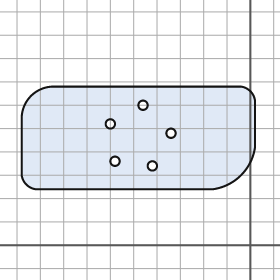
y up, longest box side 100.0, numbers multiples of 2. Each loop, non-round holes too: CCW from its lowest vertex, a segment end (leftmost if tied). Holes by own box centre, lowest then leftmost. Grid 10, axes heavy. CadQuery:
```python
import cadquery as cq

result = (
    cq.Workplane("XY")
    .moveTo(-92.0, 24.0)
    .lineTo(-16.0, 24.0)
    .threePointArc((-4.0, 30.0), (2.0, 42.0))
    .lineTo(2.0, 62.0)
    .threePointArc((0.0, 66.0), (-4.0, 68.0))
    .lineTo(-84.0, 68.0)
    .threePointArc((-94.0, 64.0), (-98.0, 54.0))
    .lineTo(-98.0, 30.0)
    .threePointArc((-96.0, 26.0), (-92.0, 24.0))
    .close()
    .moveTo(-42.0, 34.0)
    .circle(2.0)
    .moveTo(-58.0, 36.0)
    .circle(2.0)
    .moveTo(-34.0, 48.0)
    .circle(2.0)
    .moveTo(-60.0, 52.0)
    .circle(2.0)
    .moveTo(-46.0, 60.0)
    .circle(2.0)
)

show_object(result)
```